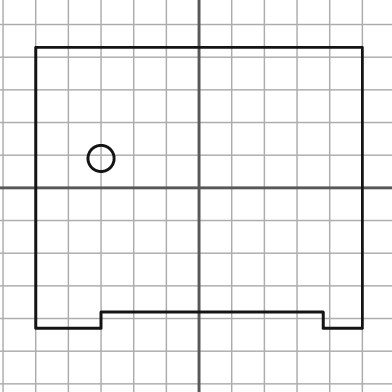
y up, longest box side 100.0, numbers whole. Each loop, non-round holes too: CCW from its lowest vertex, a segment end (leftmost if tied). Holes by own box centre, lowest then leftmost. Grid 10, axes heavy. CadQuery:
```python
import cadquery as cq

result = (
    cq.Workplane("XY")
    .moveTo(-50.0, -43.0)
    .lineTo(-30.0, -43.0)
    .lineTo(-30.0, -38.0)
    .lineTo(38.0, -38.0)
    .lineTo(38.0, -43.0)
    .lineTo(50.0, -43.0)
    .lineTo(50.0, 43.0)
    .lineTo(-50.0, 43.0)
    .close()
    .moveTo(-30.0, 9.0)
    .circle(4.0)
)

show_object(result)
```